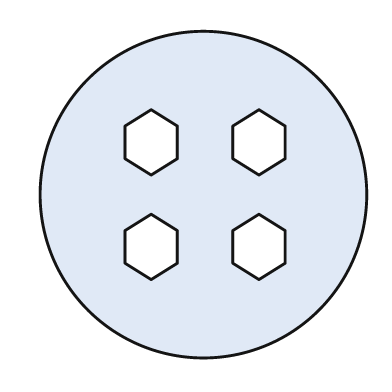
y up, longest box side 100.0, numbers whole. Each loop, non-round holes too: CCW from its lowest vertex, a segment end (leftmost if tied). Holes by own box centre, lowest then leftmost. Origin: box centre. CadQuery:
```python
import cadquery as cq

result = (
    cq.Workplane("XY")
    .moveTo(0.0, 0.0)
    .circle(50.0)
    .moveTo(-16.0, -26.0)
    .lineTo(-8.0, -21.0)
    .lineTo(-8.0, -11.0)
    .lineTo(-16.0, -6.0)
    .lineTo(-24.0, -11.0)
    .lineTo(-24.0, -21.0)
    .close()
    .moveTo(17.0, -26.0)
    .lineTo(25.0, -21.0)
    .lineTo(25.0, -11.0)
    .lineTo(17.0, -6.0)
    .lineTo(9.0, -11.0)
    .lineTo(9.0, -21.0)
    .close()
    .moveTo(-16.0, 6.0)
    .lineTo(-8.0, 11.0)
    .lineTo(-8.0, 21.0)
    .lineTo(-16.0, 26.0)
    .lineTo(-24.0, 21.0)
    .lineTo(-24.0, 11.0)
    .close()
    .moveTo(17.0, 6.0)
    .lineTo(25.0, 11.0)
    .lineTo(25.0, 21.0)
    .lineTo(17.0, 26.0)
    .lineTo(9.0, 21.0)
    .lineTo(9.0, 11.0)
    .close()
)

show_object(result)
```